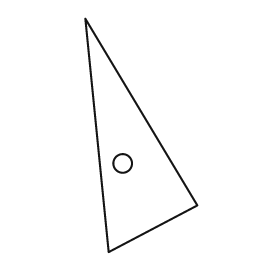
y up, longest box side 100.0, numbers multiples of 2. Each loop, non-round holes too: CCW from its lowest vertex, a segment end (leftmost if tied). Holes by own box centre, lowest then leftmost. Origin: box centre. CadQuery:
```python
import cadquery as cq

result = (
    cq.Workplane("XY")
    .moveTo(-14.0, -50.0)
    .lineTo(24.0, -30.0)
    .lineTo(-24.0, 50.0)
    .close()
    .moveTo(-8.0, -12.0)
    .circle(4.0)
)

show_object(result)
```